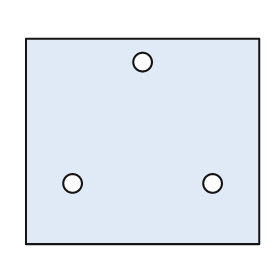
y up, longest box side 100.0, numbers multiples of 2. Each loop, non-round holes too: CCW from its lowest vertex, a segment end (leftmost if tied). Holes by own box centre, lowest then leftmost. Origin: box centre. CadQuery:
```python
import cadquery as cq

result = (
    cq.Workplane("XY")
    .moveTo(-50.0, -44.0)
    .lineTo(50.0, -44.0)
    .lineTo(50.0, 44.0)
    .lineTo(-50.0, 44.0)
    .close()
    .moveTo(-30.0, -18.0)
    .circle(4.0)
    .moveTo(30.0, -18.0)
    .circle(4.0)
    .moveTo(0.0, 34.0)
    .circle(4.0)
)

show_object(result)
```